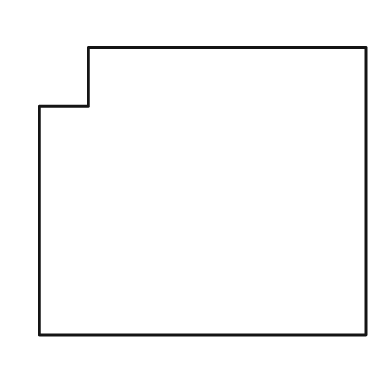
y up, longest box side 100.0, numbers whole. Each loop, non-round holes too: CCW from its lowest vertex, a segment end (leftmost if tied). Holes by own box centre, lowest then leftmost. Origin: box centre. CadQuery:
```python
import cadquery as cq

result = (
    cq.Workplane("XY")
    .moveTo(-50.0, -44.0)
    .lineTo(50.0, -44.0)
    .lineTo(50.0, 44.0)
    .lineTo(-35.0, 44.0)
    .lineTo(-35.0, 26.0)
    .lineTo(-50.0, 26.0)
    .close()
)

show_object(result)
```